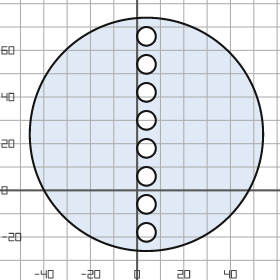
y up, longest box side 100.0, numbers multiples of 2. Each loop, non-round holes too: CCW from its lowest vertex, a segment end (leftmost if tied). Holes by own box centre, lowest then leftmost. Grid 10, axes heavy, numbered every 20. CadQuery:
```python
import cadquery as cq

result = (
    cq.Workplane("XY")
    .moveTo(4.0, 24.0)
    .circle(50.0)
    .moveTo(4.0, -18.0)
    .circle(4.0)
    .moveTo(4.0, -6.0)
    .circle(4.0)
    .moveTo(4.0, 6.0)
    .circle(4.0)
    .moveTo(4.0, 18.0)
    .circle(4.0)
    .moveTo(4.0, 30.0)
    .circle(4.0)
    .moveTo(4.0, 42.0)
    .circle(4.0)
    .moveTo(4.0, 54.0)
    .circle(4.0)
    .moveTo(4.0, 66.0)
    .circle(4.0)
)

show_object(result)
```